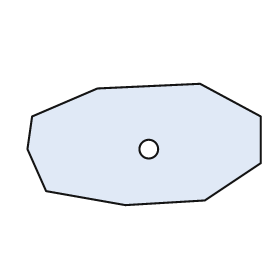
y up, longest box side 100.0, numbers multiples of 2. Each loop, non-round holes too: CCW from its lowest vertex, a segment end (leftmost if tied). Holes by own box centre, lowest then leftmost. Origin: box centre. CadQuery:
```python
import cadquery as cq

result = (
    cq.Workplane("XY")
    .moveTo(-8.0, -26.0)
    .lineTo(26.0, -24.0)
    .lineTo(50.0, -8.0)
    .lineTo(50.0, 12.0)
    .lineTo(24.0, 26.0)
    .lineTo(-20.0, 24.0)
    .lineTo(-48.0, 12.0)
    .lineTo(-50.0, -2.0)
    .lineTo(-42.0, -20.0)
    .close()
    .moveTo(2.0, -2.0)
    .circle(4.0)
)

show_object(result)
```